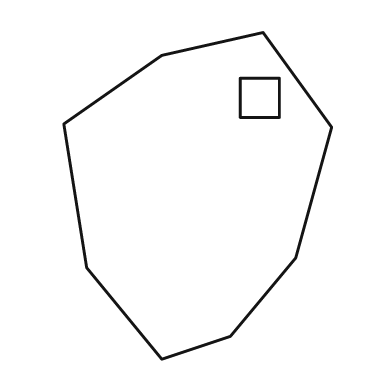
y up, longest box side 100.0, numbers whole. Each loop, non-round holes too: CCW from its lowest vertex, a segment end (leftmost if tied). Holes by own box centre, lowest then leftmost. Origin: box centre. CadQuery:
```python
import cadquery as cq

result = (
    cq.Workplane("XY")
    .moveTo(-11.0, -50.0)
    .lineTo(10.0, -43.0)
    .lineTo(30.0, -19.0)
    .lineTo(41.0, 21.0)
    .lineTo(20.0, 50.0)
    .lineTo(-11.0, 43.0)
    .lineTo(-41.0, 22.0)
    .lineTo(-34.0, -22.0)
    .close()
    .moveTo(13.0, 24.0)
    .lineTo(25.0, 24.0)
    .lineTo(25.0, 36.0)
    .lineTo(13.0, 36.0)
    .close()
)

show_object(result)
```